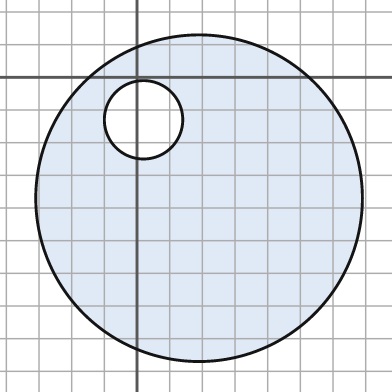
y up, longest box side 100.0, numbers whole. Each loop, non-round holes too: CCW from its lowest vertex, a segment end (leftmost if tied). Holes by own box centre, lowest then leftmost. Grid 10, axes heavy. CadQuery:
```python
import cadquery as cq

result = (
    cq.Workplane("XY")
    .moveTo(19.0, -37.0)
    .circle(50.0)
    .moveTo(2.0, -13.0)
    .circle(12.0)
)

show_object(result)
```